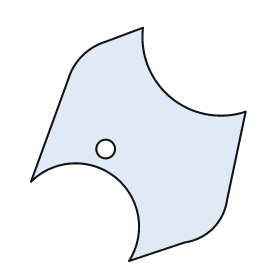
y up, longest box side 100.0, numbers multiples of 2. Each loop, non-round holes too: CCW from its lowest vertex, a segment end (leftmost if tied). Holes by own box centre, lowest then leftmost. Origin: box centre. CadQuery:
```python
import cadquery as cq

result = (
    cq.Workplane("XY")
    .moveTo(-4.0, -50.0)
    .lineTo(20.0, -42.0)
    .threePointArc((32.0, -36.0), (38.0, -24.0))
    .lineTo(46.0, 14.0)
    .threePointArc((14.0, 20.0), (2.0, 50.0))
    .lineTo(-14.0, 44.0)
    .threePointArc((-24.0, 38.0), (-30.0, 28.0))
    .lineTo(-46.0, -16.0)
    .threePointArc((-10.0, -14.0), (-4.0, -50.0))
    .close()
    .moveTo(-14.0, -2.0)
    .circle(4.0)
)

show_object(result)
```